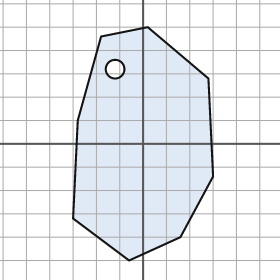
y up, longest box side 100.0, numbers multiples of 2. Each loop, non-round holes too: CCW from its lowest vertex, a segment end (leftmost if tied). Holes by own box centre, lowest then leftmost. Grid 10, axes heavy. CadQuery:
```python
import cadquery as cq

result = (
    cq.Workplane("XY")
    .moveTo(-6.0, -50.0)
    .lineTo(16.0, -40.0)
    .lineTo(30.0, -14.0)
    .lineTo(28.0, 28.0)
    .lineTo(2.0, 50.0)
    .lineTo(-18.0, 46.0)
    .lineTo(-28.0, 10.0)
    .lineTo(-30.0, -32.0)
    .close()
    .moveTo(-12.0, 32.0)
    .circle(4.0)
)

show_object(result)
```